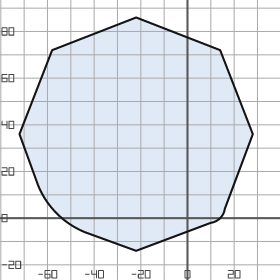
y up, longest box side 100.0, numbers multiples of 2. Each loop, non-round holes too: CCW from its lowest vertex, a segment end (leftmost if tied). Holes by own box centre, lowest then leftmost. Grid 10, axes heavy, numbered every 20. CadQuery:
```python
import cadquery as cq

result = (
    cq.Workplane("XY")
    .moveTo(-22.0, -14.0)
    .lineTo(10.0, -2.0)
    .threePointArc((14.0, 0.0), (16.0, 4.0))
    .lineTo(28.0, 36.0)
    .lineTo(14.0, 72.0)
    .lineTo(-22.0, 86.0)
    .lineTo(-58.0, 72.0)
    .lineTo(-72.0, 36.0)
    .lineTo(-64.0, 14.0)
    .threePointArc((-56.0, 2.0), (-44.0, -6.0))
    .close()
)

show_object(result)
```